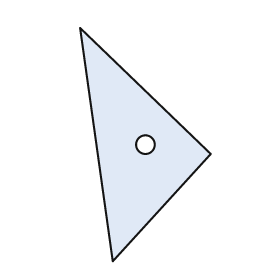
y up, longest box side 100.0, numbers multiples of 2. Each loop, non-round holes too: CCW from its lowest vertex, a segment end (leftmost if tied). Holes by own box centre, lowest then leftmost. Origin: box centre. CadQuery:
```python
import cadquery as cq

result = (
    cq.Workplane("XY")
    .moveTo(-14.0, -50.0)
    .lineTo(28.0, -4.0)
    .lineTo(-28.0, 50.0)
    .close()
    .moveTo(0.0, 0.0)
    .circle(4.0)
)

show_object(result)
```